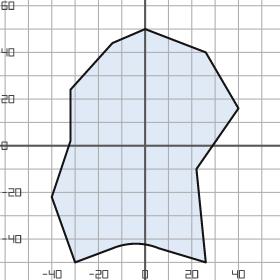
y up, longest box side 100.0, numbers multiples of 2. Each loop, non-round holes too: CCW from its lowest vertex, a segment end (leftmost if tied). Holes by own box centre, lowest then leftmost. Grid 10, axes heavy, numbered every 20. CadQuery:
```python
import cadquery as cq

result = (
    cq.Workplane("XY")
    .moveTo(-30.0, -50.0)
    .lineTo(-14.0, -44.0)
    .threePointArc((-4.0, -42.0), (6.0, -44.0))
    .lineTo(26.0, -50.0)
    .lineTo(22.0, -10.0)
    .lineTo(40.0, 16.0)
    .lineTo(26.0, 40.0)
    .lineTo(0.0, 50.0)
    .lineTo(-14.0, 44.0)
    .lineTo(-32.0, 24.0)
    .lineTo(-32.0, 2.0)
    .lineTo(-40.0, -22.0)
    .close()
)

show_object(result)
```